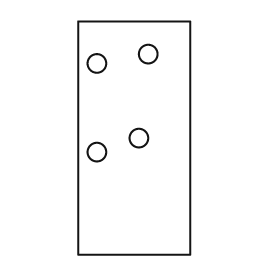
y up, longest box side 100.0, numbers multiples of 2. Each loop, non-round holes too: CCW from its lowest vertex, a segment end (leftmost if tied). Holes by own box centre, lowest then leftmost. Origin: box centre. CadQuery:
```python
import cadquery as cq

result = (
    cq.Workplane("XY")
    .moveTo(-24.0, -50.0)
    .lineTo(24.0, -50.0)
    .lineTo(24.0, 50.0)
    .lineTo(-24.0, 50.0)
    .close()
    .moveTo(-16.0, -6.0)
    .circle(4.0)
    .moveTo(2.0, 0.0)
    .circle(4.0)
    .moveTo(-16.0, 32.0)
    .circle(4.0)
    .moveTo(6.0, 36.0)
    .circle(4.0)
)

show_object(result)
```